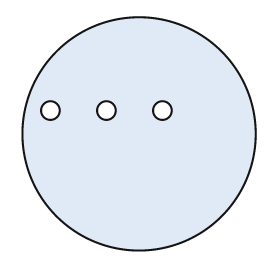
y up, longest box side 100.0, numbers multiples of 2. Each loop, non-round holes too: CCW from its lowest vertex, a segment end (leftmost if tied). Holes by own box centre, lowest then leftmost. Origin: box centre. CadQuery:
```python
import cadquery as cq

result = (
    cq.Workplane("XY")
    .moveTo(0.0, 0.0)
    .circle(50.0)
    .moveTo(-38.0, 10.0)
    .circle(4.0)
    .moveTo(-14.0, 10.0)
    .circle(4.0)
    .moveTo(10.0, 10.0)
    .circle(4.0)
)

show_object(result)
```